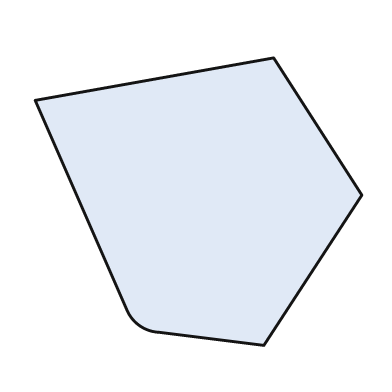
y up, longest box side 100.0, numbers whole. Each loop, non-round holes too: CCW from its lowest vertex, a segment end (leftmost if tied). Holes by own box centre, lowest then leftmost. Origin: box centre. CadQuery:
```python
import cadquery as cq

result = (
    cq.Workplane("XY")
    .moveTo(20.0, -44.0)
    .lineTo(50.0, 2.0)
    .lineTo(23.0, 44.0)
    .lineTo(-50.0, 31.0)
    .lineTo(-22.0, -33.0)
    .threePointArc((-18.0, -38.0), (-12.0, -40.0))
    .close()
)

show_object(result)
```